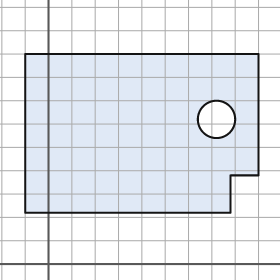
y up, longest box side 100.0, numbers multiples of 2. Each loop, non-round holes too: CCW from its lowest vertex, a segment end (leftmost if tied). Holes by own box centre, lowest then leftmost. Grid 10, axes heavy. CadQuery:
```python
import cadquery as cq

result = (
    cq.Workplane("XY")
    .moveTo(-10.0, 22.0)
    .lineTo(78.0, 22.0)
    .lineTo(78.0, 38.0)
    .lineTo(90.0, 38.0)
    .lineTo(90.0, 90.0)
    .lineTo(-10.0, 90.0)
    .close()
    .moveTo(72.0, 62.0)
    .circle(8.0)
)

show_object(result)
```